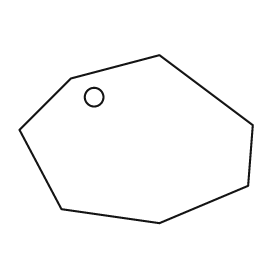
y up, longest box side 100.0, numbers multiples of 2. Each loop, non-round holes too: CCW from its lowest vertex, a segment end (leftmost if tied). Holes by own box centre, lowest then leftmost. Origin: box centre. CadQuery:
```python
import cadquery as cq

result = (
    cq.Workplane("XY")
    .moveTo(10.0, -36.0)
    .lineTo(48.0, -20.0)
    .lineTo(50.0, 6.0)
    .lineTo(10.0, 36.0)
    .lineTo(-28.0, 26.0)
    .lineTo(-50.0, 4.0)
    .lineTo(-32.0, -30.0)
    .close()
    .moveTo(-18.0, 18.0)
    .circle(4.0)
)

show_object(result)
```